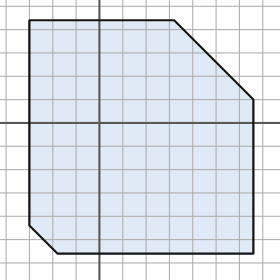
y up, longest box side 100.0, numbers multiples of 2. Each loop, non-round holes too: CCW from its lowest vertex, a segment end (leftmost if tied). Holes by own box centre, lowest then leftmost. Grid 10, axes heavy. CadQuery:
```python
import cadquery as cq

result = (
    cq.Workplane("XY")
    .moveTo(-18.0, -56.0)
    .lineTo(66.0, -56.0)
    .lineTo(66.0, 10.0)
    .lineTo(32.0, 44.0)
    .lineTo(-30.0, 44.0)
    .lineTo(-30.0, -44.0)
    .close()
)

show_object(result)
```